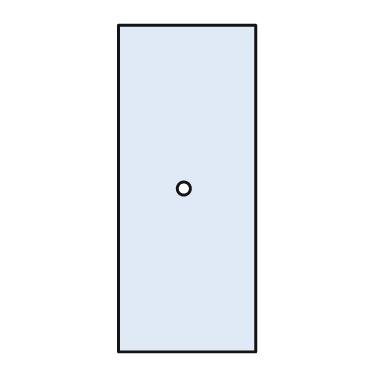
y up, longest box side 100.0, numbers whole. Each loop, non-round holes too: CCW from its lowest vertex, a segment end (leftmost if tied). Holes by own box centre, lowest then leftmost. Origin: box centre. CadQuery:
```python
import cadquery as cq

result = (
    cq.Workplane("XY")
    .moveTo(-21.0, -50.0)
    .lineTo(21.0, -50.0)
    .lineTo(21.0, 50.0)
    .lineTo(-21.0, 50.0)
    .close()
    .moveTo(-1.0, 0.0)
    .circle(2.0)
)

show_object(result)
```